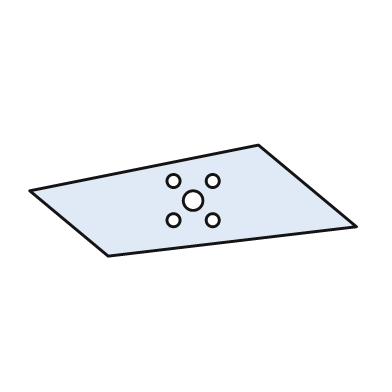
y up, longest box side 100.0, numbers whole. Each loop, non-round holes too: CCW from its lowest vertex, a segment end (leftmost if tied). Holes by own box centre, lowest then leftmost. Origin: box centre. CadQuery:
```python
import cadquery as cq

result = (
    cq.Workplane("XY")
    .moveTo(-26.0, -17.0)
    .lineTo(50.0, -8.0)
    .lineTo(20.0, 17.0)
    .lineTo(-50.0, 3.0)
    .close()
    .moveTo(-6.0, -6.0)
    .circle(2.0)
    .moveTo(6.0, -6.0)
    .circle(2.0)
    .moveTo(0.0, 0.0)
    .circle(3.0)
    .moveTo(-6.0, 6.0)
    .circle(2.0)
    .moveTo(6.0, 6.0)
    .circle(2.0)
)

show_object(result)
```